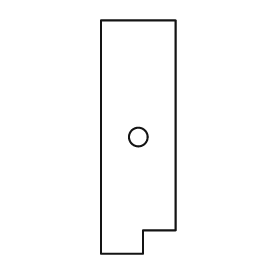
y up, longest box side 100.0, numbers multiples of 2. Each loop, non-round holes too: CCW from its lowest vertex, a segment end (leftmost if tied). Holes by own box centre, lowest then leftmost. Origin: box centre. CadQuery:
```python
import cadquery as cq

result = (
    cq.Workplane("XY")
    .moveTo(-16.0, -50.0)
    .lineTo(2.0, -50.0)
    .lineTo(2.0, -40.0)
    .lineTo(16.0, -40.0)
    .lineTo(16.0, 50.0)
    .lineTo(-16.0, 50.0)
    .close()
    .moveTo(0.0, 0.0)
    .circle(4.0)
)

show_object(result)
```